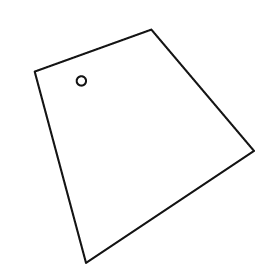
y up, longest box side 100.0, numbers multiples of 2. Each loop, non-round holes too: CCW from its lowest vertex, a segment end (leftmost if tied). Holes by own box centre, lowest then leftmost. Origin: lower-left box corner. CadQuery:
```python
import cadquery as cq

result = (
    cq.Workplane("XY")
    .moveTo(22.0, 0.0)
    .lineTo(94.0, 48.0)
    .lineTo(50.0, 100.0)
    .lineTo(0.0, 82.0)
    .close()
    .moveTo(20.0, 78.0)
    .circle(2.0)
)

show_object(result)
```